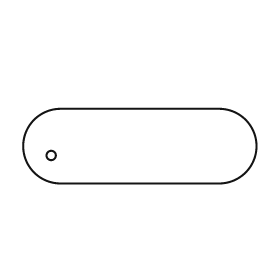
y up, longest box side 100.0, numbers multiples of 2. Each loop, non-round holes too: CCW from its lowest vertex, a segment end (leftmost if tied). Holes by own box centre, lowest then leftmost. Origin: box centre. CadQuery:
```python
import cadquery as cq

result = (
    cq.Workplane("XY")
    .moveTo(-34.0, -16.0)
    .lineTo(34.0, -16.0)
    .threePointArc((50.0, 0.0), (34.0, 16.0))
    .lineTo(-34.0, 16.0)
    .threePointArc((-50.0, 0.0), (-34.0, -16.0))
    .close()
    .moveTo(-38.0, -4.0)
    .circle(2.0)
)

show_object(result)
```